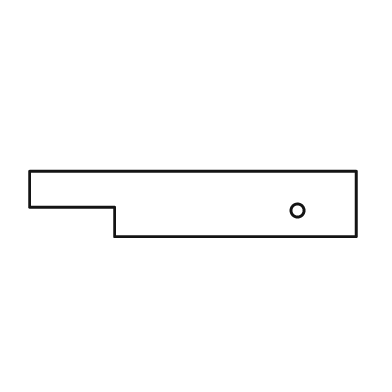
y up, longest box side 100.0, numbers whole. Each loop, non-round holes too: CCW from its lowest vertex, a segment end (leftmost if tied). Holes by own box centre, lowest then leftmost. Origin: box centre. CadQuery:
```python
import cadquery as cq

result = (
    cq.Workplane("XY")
    .moveTo(-24.0, -10.0)
    .lineTo(50.0, -10.0)
    .lineTo(50.0, 10.0)
    .lineTo(-50.0, 10.0)
    .lineTo(-50.0, -1.0)
    .lineTo(-24.0, -1.0)
    .close()
    .moveTo(32.0, -2.0)
    .circle(2.0)
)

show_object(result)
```